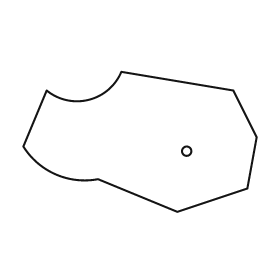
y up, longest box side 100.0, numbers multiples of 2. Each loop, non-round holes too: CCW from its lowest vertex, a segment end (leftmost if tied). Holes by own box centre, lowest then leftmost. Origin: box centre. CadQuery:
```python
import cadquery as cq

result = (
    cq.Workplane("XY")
    .moveTo(16.0, -30.0)
    .lineTo(46.0, -20.0)
    .lineTo(50.0, 2.0)
    .lineTo(40.0, 22.0)
    .lineTo(-8.0, 30.0)
    .threePointArc((-22.0, 18.0), (-40.0, 22.0))
    .lineTo(-50.0, -2.0)
    .threePointArc((-36.0, -14.0), (-18.0, -16.0))
    .close()
    .moveTo(20.0, -4.0)
    .circle(2.0)
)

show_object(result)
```